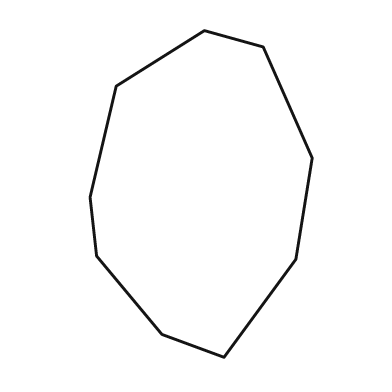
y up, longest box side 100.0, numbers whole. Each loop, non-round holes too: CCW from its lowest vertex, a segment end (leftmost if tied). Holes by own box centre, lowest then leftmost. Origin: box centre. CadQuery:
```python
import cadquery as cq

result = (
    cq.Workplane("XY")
    .moveTo(7.0, -50.0)
    .lineTo(29.0, -20.0)
    .lineTo(34.0, 11.0)
    .lineTo(19.0, 45.0)
    .lineTo(1.0, 50.0)
    .lineTo(-26.0, 33.0)
    .lineTo(-34.0, -1.0)
    .lineTo(-32.0, -19.0)
    .lineTo(-12.0, -43.0)
    .close()
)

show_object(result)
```